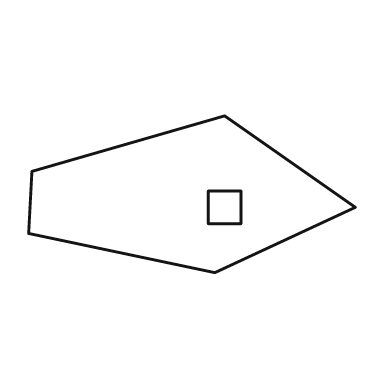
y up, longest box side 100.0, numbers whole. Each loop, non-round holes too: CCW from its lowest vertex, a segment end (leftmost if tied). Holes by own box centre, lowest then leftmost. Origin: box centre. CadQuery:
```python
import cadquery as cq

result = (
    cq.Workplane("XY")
    .moveTo(7.0, -24.0)
    .lineTo(50.0, -4.0)
    .lineTo(10.0, 24.0)
    .lineTo(-49.0, 7.0)
    .lineTo(-50.0, -12.0)
    .close()
    .moveTo(5.0, -9.0)
    .lineTo(15.0, -9.0)
    .lineTo(15.0, 1.0)
    .lineTo(5.0, 1.0)
    .close()
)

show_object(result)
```